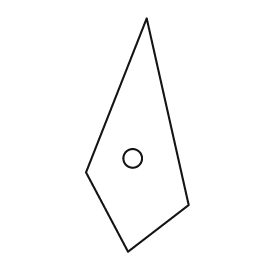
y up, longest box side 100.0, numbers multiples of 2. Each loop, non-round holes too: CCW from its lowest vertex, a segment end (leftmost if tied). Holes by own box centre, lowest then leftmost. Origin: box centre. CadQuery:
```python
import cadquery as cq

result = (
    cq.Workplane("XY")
    .moveTo(-4.0, -50.0)
    .lineTo(22.0, -30.0)
    .lineTo(4.0, 50.0)
    .lineTo(-22.0, -16.0)
    .close()
    .moveTo(-2.0, -10.0)
    .circle(4.0)
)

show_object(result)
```